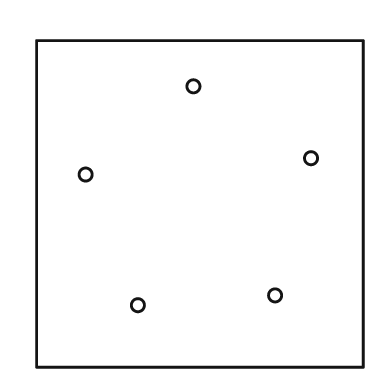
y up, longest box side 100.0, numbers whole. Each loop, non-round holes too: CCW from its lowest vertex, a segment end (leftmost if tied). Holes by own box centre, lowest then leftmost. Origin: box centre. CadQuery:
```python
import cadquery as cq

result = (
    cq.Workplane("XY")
    .moveTo(-50.0, -50.0)
    .lineTo(50.0, -50.0)
    .lineTo(50.0, 50.0)
    .lineTo(-50.0, 50.0)
    .close()
    .moveTo(-19.0, -31.0)
    .circle(2.0)
    .moveTo(23.0, -28.0)
    .circle(2.0)
    .moveTo(-35.0, 9.0)
    .circle(2.0)
    .moveTo(34.0, 14.0)
    .circle(2.0)
    .moveTo(-2.0, 36.0)
    .circle(2.0)
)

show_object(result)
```